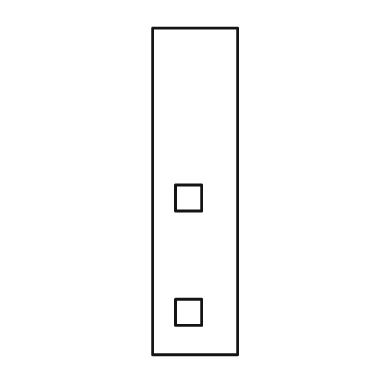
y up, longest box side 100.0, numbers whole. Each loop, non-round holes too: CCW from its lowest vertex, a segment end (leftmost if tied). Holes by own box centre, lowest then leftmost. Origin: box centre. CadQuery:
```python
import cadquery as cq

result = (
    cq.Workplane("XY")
    .moveTo(-13.0, -50.0)
    .lineTo(13.0, -50.0)
    .lineTo(13.0, 50.0)
    .lineTo(-13.0, 50.0)
    .close()
    .moveTo(-6.0, -41.0)
    .lineTo(2.0, -41.0)
    .lineTo(2.0, -33.0)
    .lineTo(-6.0, -33.0)
    .close()
    .moveTo(-6.0, -6.0)
    .lineTo(2.0, -6.0)
    .lineTo(2.0, 2.0)
    .lineTo(-6.0, 2.0)
    .close()
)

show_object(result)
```